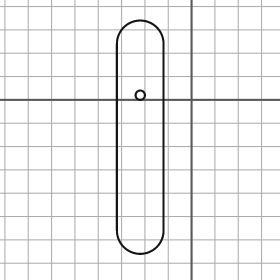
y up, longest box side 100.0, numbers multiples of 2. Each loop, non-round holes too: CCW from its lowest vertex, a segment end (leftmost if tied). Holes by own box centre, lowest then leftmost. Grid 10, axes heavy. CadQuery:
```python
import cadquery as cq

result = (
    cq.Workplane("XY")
    .moveTo(-32.0, -56.0)
    .threePointArc((-22.0, -66.0), (-12.0, -56.0))
    .lineTo(-12.0, 24.0)
    .threePointArc((-22.0, 34.0), (-32.0, 24.0))
    .close()
    .moveTo(-22.0, 2.0)
    .circle(2.0)
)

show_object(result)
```